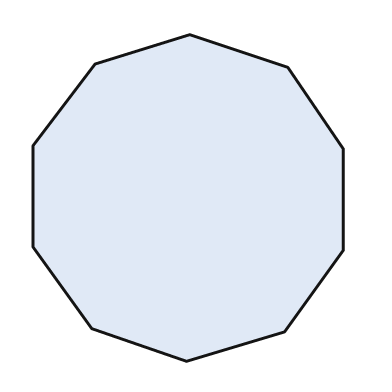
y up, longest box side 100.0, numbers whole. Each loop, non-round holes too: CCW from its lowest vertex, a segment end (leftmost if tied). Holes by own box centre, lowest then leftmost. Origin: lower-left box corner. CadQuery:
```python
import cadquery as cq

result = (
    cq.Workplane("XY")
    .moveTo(47.0, 0.0)
    .lineTo(77.0, 9.0)
    .lineTo(95.0, 34.0)
    .lineTo(95.0, 65.0)
    .lineTo(78.0, 90.0)
    .lineTo(48.0, 100.0)
    .lineTo(19.0, 91.0)
    .lineTo(0.0, 66.0)
    .lineTo(0.0, 35.0)
    .lineTo(18.0, 10.0)
    .close()
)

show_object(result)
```